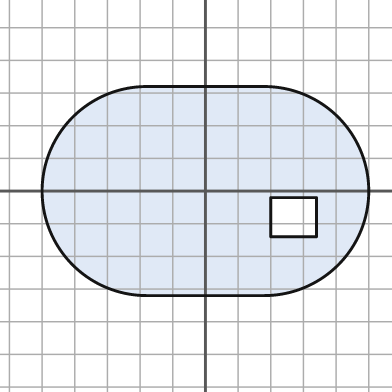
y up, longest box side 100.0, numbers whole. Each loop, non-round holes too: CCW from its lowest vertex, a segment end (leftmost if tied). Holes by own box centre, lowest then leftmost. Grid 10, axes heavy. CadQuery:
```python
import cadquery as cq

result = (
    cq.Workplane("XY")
    .moveTo(-18.0, -32.0)
    .lineTo(18.0, -32.0)
    .threePointArc((50.0, 0.0), (18.0, 32.0))
    .lineTo(-18.0, 32.0)
    .threePointArc((-50.0, 0.0), (-18.0, -32.0))
    .close()
    .moveTo(20.0, -14.0)
    .lineTo(34.0, -14.0)
    .lineTo(34.0, -2.0)
    .lineTo(20.0, -2.0)
    .close()
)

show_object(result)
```